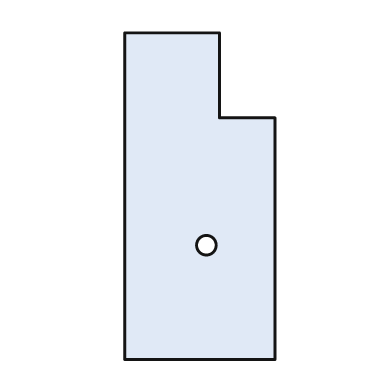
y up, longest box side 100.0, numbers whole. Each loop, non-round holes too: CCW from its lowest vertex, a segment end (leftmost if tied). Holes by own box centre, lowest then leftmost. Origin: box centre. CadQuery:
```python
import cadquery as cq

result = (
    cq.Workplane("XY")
    .moveTo(-23.0, -50.0)
    .lineTo(23.0, -50.0)
    .lineTo(23.0, 24.0)
    .lineTo(6.0, 24.0)
    .lineTo(6.0, 50.0)
    .lineTo(-23.0, 50.0)
    .close()
    .moveTo(2.0, -15.0)
    .circle(3.0)
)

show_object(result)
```